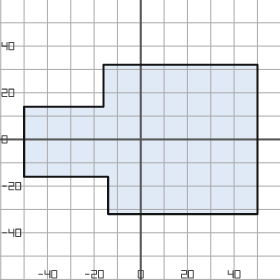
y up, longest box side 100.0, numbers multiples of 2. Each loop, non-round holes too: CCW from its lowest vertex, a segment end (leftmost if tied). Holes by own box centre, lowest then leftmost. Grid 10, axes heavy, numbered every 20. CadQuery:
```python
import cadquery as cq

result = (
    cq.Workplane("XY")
    .moveTo(-14.0, -32.0)
    .lineTo(50.0, -32.0)
    .lineTo(50.0, 32.0)
    .lineTo(-16.0, 32.0)
    .lineTo(-16.0, 14.0)
    .lineTo(-50.0, 14.0)
    .lineTo(-50.0, -16.0)
    .lineTo(-14.0, -16.0)
    .close()
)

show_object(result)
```